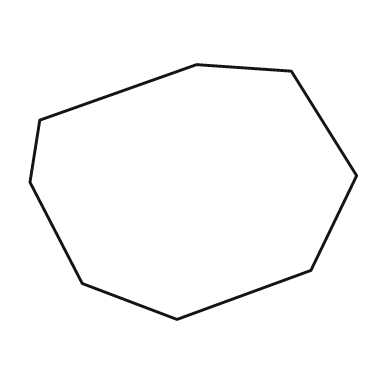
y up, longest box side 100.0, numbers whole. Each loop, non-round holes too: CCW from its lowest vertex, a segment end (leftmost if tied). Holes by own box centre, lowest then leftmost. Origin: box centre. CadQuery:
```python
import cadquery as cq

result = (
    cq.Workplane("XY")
    .moveTo(-5.0, -39.0)
    .lineTo(36.0, -24.0)
    .lineTo(50.0, 5.0)
    .lineTo(30.0, 37.0)
    .lineTo(1.0, 39.0)
    .lineTo(-47.0, 22.0)
    .lineTo(-50.0, 3.0)
    .lineTo(-34.0, -28.0)
    .close()
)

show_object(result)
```